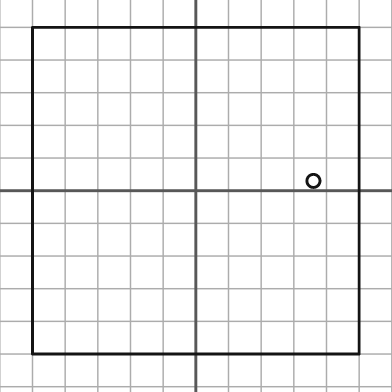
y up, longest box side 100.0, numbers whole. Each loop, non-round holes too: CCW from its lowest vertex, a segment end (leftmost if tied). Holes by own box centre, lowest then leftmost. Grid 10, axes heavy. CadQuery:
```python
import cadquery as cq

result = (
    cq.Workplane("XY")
    .moveTo(-50.0, -50.0)
    .lineTo(50.0, -50.0)
    .lineTo(50.0, 50.0)
    .lineTo(-50.0, 50.0)
    .close()
    .moveTo(36.0, 3.0)
    .circle(2.0)
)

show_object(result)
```